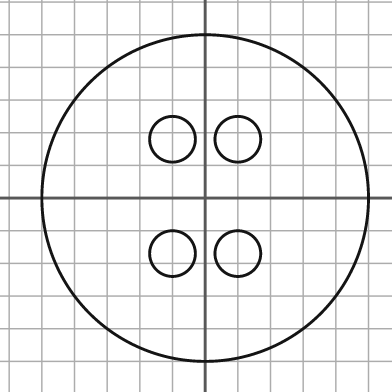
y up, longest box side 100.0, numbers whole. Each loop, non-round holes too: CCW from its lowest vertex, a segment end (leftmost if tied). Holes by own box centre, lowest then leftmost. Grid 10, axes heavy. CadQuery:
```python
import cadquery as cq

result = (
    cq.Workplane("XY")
    .moveTo(0.0, 0.0)
    .circle(50.0)
    .moveTo(-10.0, -17.0)
    .circle(7.0)
    .moveTo(10.0, -17.0)
    .circle(7.0)
    .moveTo(-10.0, 18.0)
    .circle(7.0)
    .moveTo(10.0, 18.0)
    .circle(7.0)
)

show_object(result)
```